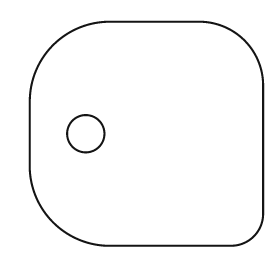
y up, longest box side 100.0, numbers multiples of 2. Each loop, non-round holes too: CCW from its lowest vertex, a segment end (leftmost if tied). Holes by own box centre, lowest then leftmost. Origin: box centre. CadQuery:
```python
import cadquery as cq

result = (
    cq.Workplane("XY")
    .moveTo(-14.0, -48.0)
    .lineTo(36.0, -48.0)
    .threePointArc((46.0, -44.0), (50.0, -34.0))
    .lineTo(50.0, 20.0)
    .threePointArc((42.0, 40.0), (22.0, 48.0))
    .lineTo(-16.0, 48.0)
    .threePointArc((-40.0, 38.0), (-50.0, 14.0))
    .lineTo(-50.0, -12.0)
    .threePointArc((-40.0, -38.0), (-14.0, -48.0))
    .close()
    .moveTo(-26.0, 0.0)
    .circle(8.0)
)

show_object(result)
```